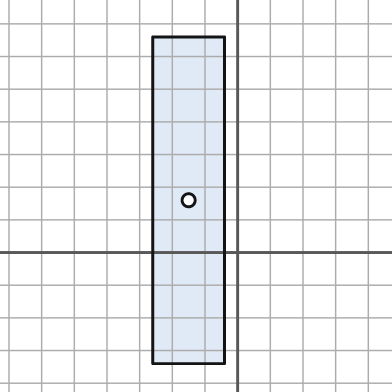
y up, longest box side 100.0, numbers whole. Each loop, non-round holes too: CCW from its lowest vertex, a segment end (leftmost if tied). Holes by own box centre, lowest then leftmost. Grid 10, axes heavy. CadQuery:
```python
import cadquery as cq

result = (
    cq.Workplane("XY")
    .moveTo(-26.0, -34.0)
    .lineTo(-4.0, -34.0)
    .lineTo(-4.0, 66.0)
    .lineTo(-26.0, 66.0)
    .close()
    .moveTo(-15.0, 16.0)
    .circle(2.0)
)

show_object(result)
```